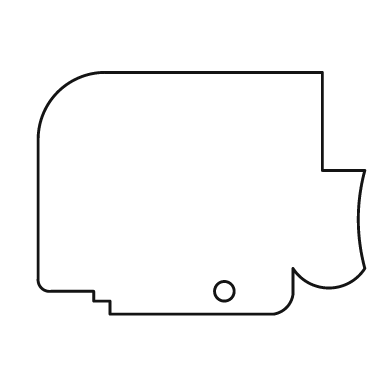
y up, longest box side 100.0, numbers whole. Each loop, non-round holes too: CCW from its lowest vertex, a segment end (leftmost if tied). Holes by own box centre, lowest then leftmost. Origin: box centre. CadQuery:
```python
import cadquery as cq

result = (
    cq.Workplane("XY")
    .moveTo(-28.0, -37.0)
    .lineTo(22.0, -37.0)
    .threePointArc((26.0, -35.0), (28.0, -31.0))
    .lineTo(28.0, -23.0)
    .threePointArc((39.0, -29.0), (50.0, -23.0))
    .threePointArc((48.0, -8.0), (50.0, 7.0))
    .lineTo(37.0, 7.0)
    .lineTo(37.0, 37.0)
    .lineTo(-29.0, 37.0)
    .threePointArc((-44.0, 31.0), (-50.0, 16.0))
    .lineTo(-50.0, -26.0)
    .threePointArc((-49.0, -29.0), (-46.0, -30.0))
    .lineTo(-33.0, -30.0)
    .lineTo(-33.0, -33.0)
    .lineTo(-28.0, -33.0)
    .close()
    .moveTo(7.0, -30.0)
    .circle(3.0)
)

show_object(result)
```